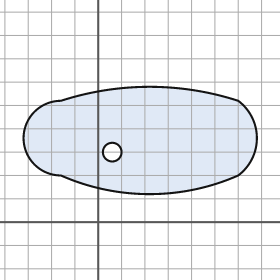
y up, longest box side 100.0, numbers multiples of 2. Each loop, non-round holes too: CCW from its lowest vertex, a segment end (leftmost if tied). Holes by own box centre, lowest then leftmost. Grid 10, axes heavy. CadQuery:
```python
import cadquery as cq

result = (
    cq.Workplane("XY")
    .moveTo(-16.0, 20.0)
    .threePointArc((22.0, 12.0), (60.0, 20.0))
    .threePointArc((68.0, 36.0), (60.0, 52.0))
    .threePointArc((22.0, 58.0), (-16.0, 52.0))
    .threePointArc((-32.0, 36.0), (-16.0, 20.0))
    .close()
    .moveTo(6.0, 30.0)
    .circle(4.0)
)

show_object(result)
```